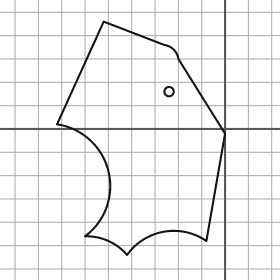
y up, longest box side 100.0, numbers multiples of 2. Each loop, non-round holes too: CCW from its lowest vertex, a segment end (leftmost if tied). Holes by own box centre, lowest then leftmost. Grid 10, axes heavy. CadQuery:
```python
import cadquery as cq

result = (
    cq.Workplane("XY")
    .moveTo(-42.0, -54.0)
    .threePointArc((-26.0, -44.0), (-8.0, -48.0))
    .lineTo(0.0, -2.0)
    .lineTo(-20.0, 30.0)
    .threePointArc((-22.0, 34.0), (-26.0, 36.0))
    .lineTo(-52.0, 46.0)
    .lineTo(-72.0, 2.0)
    .threePointArc((-50.0, -18.0), (-60.0, -46.0))
    .threePointArc((-50.0, -48.0), (-42.0, -54.0))
    .close()
    .moveTo(-24.0, 16.0)
    .circle(2.0)
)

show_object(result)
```